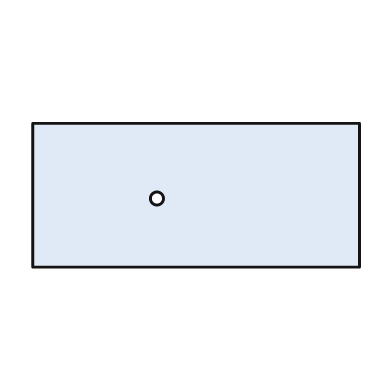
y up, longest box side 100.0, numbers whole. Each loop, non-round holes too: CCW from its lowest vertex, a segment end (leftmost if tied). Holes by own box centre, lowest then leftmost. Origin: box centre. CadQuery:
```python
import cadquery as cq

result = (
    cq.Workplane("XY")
    .moveTo(-50.0, -22.0)
    .lineTo(50.0, -22.0)
    .lineTo(50.0, 22.0)
    .lineTo(-50.0, 22.0)
    .close()
    .moveTo(-12.0, -1.0)
    .circle(2.0)
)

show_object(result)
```